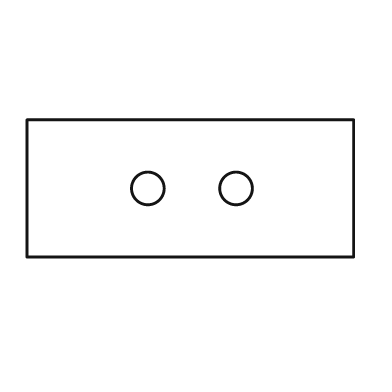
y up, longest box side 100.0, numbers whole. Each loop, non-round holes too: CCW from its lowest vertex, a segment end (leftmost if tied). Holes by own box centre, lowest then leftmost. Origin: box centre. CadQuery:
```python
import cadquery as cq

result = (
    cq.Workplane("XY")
    .moveTo(-50.0, -21.0)
    .lineTo(50.0, -21.0)
    .lineTo(50.0, 21.0)
    .lineTo(-50.0, 21.0)
    .close()
    .moveTo(-13.0, 0.0)
    .circle(5.0)
    .moveTo(14.0, 0.0)
    .circle(5.0)
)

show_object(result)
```